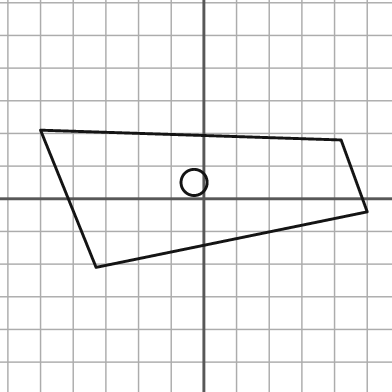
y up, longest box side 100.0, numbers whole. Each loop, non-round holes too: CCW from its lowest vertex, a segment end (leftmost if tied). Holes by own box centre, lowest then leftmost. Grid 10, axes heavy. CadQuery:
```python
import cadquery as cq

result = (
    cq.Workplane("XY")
    .moveTo(-33.0, -21.0)
    .lineTo(50.0, -4.0)
    .lineTo(42.0, 18.0)
    .lineTo(-50.0, 21.0)
    .close()
    .moveTo(-3.0, 5.0)
    .circle(4.0)
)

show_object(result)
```